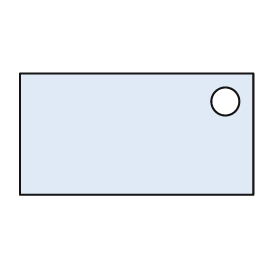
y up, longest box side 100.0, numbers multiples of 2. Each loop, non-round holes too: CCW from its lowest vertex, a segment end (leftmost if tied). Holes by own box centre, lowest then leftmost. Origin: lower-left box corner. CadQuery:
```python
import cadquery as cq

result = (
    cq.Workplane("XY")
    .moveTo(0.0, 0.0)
    .lineTo(100.0, 0.0)
    .lineTo(100.0, 52.0)
    .lineTo(0.0, 52.0)
    .close()
    .moveTo(88.0, 40.0)
    .circle(6.0)
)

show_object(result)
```